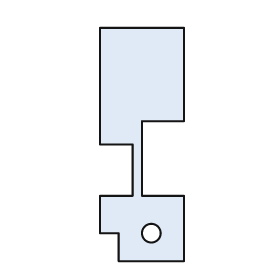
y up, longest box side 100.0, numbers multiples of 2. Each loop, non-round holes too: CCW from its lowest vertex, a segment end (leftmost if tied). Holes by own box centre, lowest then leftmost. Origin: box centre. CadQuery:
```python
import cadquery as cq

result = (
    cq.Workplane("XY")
    .moveTo(-10.0, -50.0)
    .lineTo(18.0, -50.0)
    .lineTo(18.0, -22.0)
    .lineTo(0.0, -22.0)
    .lineTo(0.0, 10.0)
    .lineTo(18.0, 10.0)
    .lineTo(18.0, 50.0)
    .lineTo(-18.0, 50.0)
    .lineTo(-18.0, 0.0)
    .lineTo(-4.0, 0.0)
    .lineTo(-4.0, -22.0)
    .lineTo(-18.0, -22.0)
    .lineTo(-18.0, -38.0)
    .lineTo(-10.0, -38.0)
    .close()
    .moveTo(4.0, -38.0)
    .circle(4.0)
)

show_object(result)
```